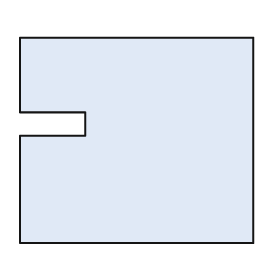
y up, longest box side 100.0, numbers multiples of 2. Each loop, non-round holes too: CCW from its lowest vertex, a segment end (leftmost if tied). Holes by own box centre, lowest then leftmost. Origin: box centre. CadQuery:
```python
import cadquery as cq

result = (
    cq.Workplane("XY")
    .moveTo(-50.0, -44.0)
    .lineTo(50.0, -44.0)
    .lineTo(50.0, 44.0)
    .lineTo(-50.0, 44.0)
    .lineTo(-50.0, 12.0)
    .lineTo(-22.0, 12.0)
    .lineTo(-22.0, 2.0)
    .lineTo(-50.0, 2.0)
    .close()
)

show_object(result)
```